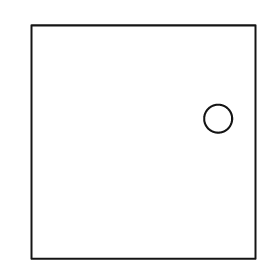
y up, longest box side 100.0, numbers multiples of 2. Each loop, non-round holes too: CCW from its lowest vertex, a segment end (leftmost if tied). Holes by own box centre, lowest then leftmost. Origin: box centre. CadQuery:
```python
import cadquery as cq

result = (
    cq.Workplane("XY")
    .moveTo(-48.0, -50.0)
    .lineTo(48.0, -50.0)
    .lineTo(48.0, 50.0)
    .lineTo(-48.0, 50.0)
    .close()
    .moveTo(32.0, 10.0)
    .circle(6.0)
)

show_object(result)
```